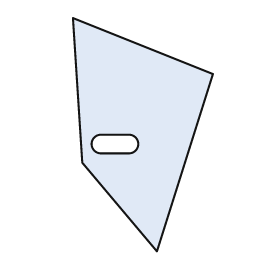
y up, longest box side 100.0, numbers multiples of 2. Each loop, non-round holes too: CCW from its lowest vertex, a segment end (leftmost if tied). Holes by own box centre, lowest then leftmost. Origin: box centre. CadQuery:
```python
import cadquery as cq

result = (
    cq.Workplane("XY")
    .moveTo(6.0, -50.0)
    .lineTo(30.0, 26.0)
    .lineTo(-30.0, 50.0)
    .lineTo(-26.0, -12.0)
    .close()
    .moveTo(-18.0, -8.0)
    .lineTo(-6.0, -8.0)
    .threePointArc((-2.0, -4.0), (-6.0, 0.0))
    .lineTo(-18.0, 0.0)
    .threePointArc((-22.0, -4.0), (-18.0, -8.0))
    .close()
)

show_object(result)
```